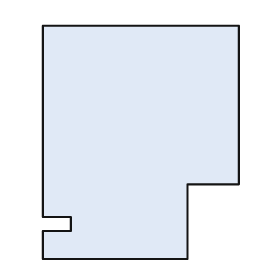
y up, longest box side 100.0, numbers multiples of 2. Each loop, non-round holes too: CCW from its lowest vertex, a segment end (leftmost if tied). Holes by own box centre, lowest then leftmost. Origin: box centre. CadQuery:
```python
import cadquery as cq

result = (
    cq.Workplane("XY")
    .moveTo(-42.0, -50.0)
    .lineTo(20.0, -50.0)
    .lineTo(20.0, -18.0)
    .lineTo(42.0, -18.0)
    .lineTo(42.0, 50.0)
    .lineTo(-42.0, 50.0)
    .lineTo(-42.0, -32.0)
    .lineTo(-30.0, -32.0)
    .lineTo(-30.0, -38.0)
    .lineTo(-42.0, -38.0)
    .close()
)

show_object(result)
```